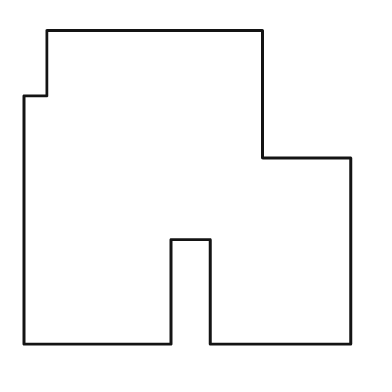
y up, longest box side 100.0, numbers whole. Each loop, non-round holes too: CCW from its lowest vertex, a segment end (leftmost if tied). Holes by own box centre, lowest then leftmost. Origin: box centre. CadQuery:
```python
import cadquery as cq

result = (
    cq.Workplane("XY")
    .moveTo(-50.0, -48.0)
    .lineTo(-5.0, -48.0)
    .lineTo(-5.0, -16.0)
    .lineTo(7.0, -16.0)
    .lineTo(7.0, -48.0)
    .lineTo(50.0, -48.0)
    .lineTo(50.0, 9.0)
    .lineTo(23.0, 9.0)
    .lineTo(23.0, 48.0)
    .lineTo(-43.0, 48.0)
    .lineTo(-43.0, 28.0)
    .lineTo(-50.0, 28.0)
    .close()
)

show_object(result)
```